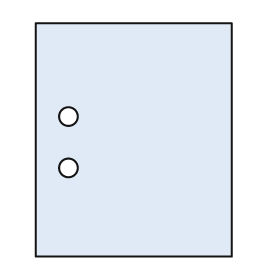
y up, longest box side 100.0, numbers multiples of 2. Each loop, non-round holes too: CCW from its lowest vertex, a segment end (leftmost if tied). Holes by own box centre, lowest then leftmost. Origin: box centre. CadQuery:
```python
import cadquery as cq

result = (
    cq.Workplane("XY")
    .moveTo(-42.0, -50.0)
    .lineTo(42.0, -50.0)
    .lineTo(42.0, 50.0)
    .lineTo(-42.0, 50.0)
    .close()
    .moveTo(-28.0, -12.0)
    .circle(4.0)
    .moveTo(-28.0, 10.0)
    .circle(4.0)
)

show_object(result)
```